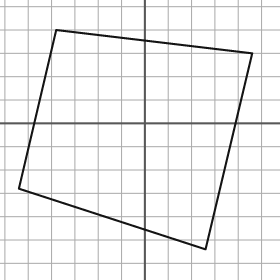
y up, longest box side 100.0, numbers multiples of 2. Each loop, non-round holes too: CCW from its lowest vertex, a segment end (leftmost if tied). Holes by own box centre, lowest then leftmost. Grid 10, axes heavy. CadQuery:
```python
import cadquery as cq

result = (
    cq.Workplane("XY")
    .moveTo(26.0, -54.0)
    .lineTo(46.0, 30.0)
    .lineTo(-38.0, 40.0)
    .lineTo(-54.0, -28.0)
    .close()
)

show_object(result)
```